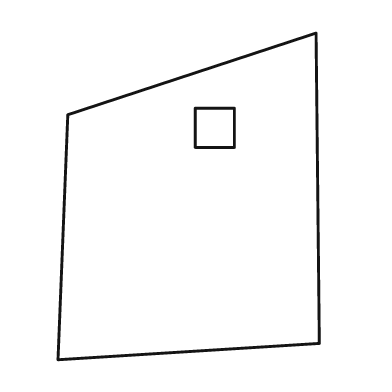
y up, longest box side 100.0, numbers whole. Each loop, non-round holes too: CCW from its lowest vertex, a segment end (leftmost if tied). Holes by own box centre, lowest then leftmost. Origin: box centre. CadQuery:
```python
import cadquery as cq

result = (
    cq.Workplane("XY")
    .moveTo(-40.0, -50.0)
    .lineTo(40.0, -45.0)
    .lineTo(39.0, 50.0)
    .lineTo(-37.0, 25.0)
    .close()
    .moveTo(2.0, 15.0)
    .lineTo(14.0, 15.0)
    .lineTo(14.0, 27.0)
    .lineTo(2.0, 27.0)
    .close()
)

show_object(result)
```